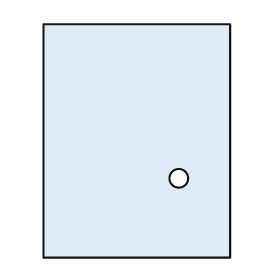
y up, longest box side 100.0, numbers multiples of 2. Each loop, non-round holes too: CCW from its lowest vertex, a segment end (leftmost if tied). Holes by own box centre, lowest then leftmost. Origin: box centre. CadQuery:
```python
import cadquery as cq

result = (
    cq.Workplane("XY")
    .moveTo(-40.0, -50.0)
    .lineTo(40.0, -50.0)
    .lineTo(40.0, 50.0)
    .lineTo(-40.0, 50.0)
    .close()
    .moveTo(18.0, -16.0)
    .circle(4.0)
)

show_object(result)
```